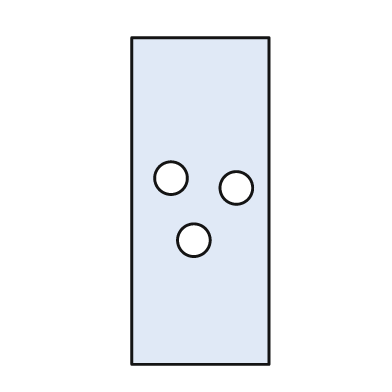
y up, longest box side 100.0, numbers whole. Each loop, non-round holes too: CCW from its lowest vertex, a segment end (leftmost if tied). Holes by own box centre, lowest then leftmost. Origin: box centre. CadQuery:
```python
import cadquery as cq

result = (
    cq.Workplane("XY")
    .moveTo(-21.0, -50.0)
    .lineTo(21.0, -50.0)
    .lineTo(21.0, 50.0)
    .lineTo(-21.0, 50.0)
    .close()
    .moveTo(-2.0, -12.0)
    .circle(5.0)
    .moveTo(11.0, 4.0)
    .circle(5.0)
    .moveTo(-9.0, 7.0)
    .circle(5.0)
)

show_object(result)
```